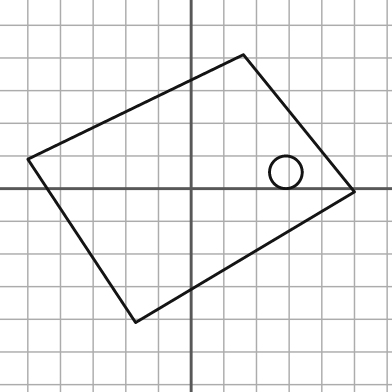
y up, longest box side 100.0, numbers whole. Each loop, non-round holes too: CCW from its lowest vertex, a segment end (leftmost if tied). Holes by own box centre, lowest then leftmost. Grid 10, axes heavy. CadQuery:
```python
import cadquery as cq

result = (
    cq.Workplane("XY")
    .moveTo(-17.0, -41.0)
    .lineTo(50.0, -1.0)
    .lineTo(16.0, 41.0)
    .lineTo(-50.0, 9.0)
    .close()
    .moveTo(29.0, 5.0)
    .circle(5.0)
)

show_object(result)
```